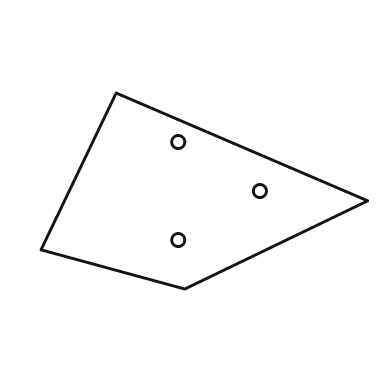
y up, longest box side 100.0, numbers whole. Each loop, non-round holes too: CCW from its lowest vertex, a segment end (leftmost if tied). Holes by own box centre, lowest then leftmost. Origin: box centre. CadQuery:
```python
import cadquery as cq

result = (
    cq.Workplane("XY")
    .moveTo(-6.0, -30.0)
    .lineTo(50.0, -3.0)
    .lineTo(-27.0, 30.0)
    .lineTo(-50.0, -18.0)
    .close()
    .moveTo(-8.0, -15.0)
    .circle(2.0)
    .moveTo(17.0, 0.0)
    .circle(2.0)
    .moveTo(-8.0, 15.0)
    .circle(2.0)
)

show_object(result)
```